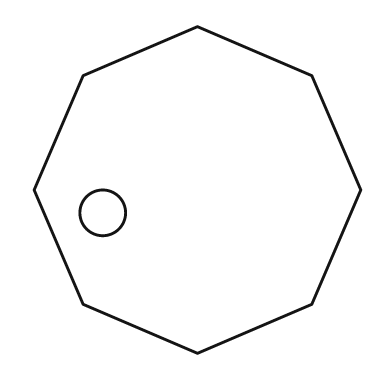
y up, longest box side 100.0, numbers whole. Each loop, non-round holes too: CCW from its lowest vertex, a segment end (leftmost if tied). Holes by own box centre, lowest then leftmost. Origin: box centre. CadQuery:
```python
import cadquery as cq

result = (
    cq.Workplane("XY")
    .moveTo(0.0, -50.0)
    .lineTo(35.0, -35.0)
    .lineTo(50.0, 0.0)
    .lineTo(35.0, 35.0)
    .lineTo(0.0, 50.0)
    .lineTo(-35.0, 35.0)
    .lineTo(-50.0, 0.0)
    .lineTo(-35.0, -35.0)
    .close()
    .moveTo(-29.0, -7.0)
    .circle(7.0)
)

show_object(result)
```